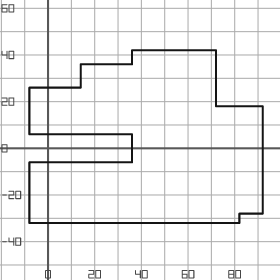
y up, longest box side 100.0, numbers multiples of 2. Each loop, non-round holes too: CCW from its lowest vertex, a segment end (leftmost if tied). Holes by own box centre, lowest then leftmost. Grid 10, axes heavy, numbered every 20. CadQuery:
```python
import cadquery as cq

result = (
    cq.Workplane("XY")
    .moveTo(-8.0, -32.0)
    .lineTo(82.0, -32.0)
    .lineTo(82.0, -28.0)
    .lineTo(92.0, -28.0)
    .lineTo(92.0, 18.0)
    .lineTo(72.0, 18.0)
    .lineTo(72.0, 42.0)
    .lineTo(36.0, 42.0)
    .lineTo(36.0, 36.0)
    .lineTo(14.0, 36.0)
    .lineTo(14.0, 26.0)
    .lineTo(-8.0, 26.0)
    .lineTo(-8.0, 6.0)
    .lineTo(36.0, 6.0)
    .lineTo(36.0, -6.0)
    .lineTo(-8.0, -6.0)
    .close()
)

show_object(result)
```